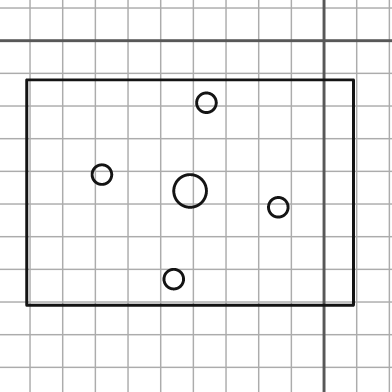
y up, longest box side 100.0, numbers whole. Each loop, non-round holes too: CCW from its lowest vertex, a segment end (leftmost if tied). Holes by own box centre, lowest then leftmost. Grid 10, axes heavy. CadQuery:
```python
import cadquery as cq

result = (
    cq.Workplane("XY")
    .moveTo(-91.0, -81.0)
    .lineTo(9.0, -81.0)
    .lineTo(9.0, -12.0)
    .lineTo(-91.0, -12.0)
    .close()
    .moveTo(-46.0, -73.0)
    .circle(3.0)
    .moveTo(-14.0, -51.0)
    .circle(3.0)
    .moveTo(-41.0, -46.0)
    .circle(5.0)
    .moveTo(-68.0, -41.0)
    .circle(3.0)
    .moveTo(-36.0, -19.0)
    .circle(3.0)
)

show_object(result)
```